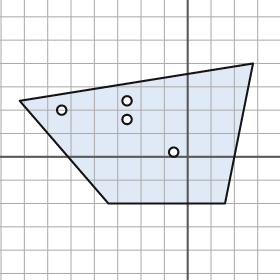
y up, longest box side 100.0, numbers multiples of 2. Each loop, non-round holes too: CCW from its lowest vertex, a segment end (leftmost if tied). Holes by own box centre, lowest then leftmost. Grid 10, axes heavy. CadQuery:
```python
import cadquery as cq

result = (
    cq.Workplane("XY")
    .moveTo(-34.0, -20.0)
    .lineTo(16.0, -20.0)
    .lineTo(28.0, 40.0)
    .lineTo(-72.0, 24.0)
    .close()
    .moveTo(-6.0, 2.0)
    .circle(2.0)
    .moveTo(-26.0, 16.0)
    .circle(2.0)
    .moveTo(-54.0, 20.0)
    .circle(2.0)
    .moveTo(-26.0, 24.0)
    .circle(2.0)
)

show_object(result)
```